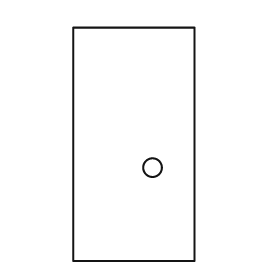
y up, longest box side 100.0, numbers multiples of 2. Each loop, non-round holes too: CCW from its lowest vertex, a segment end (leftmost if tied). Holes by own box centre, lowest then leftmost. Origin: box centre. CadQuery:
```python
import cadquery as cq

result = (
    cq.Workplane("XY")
    .moveTo(-26.0, -50.0)
    .lineTo(26.0, -50.0)
    .lineTo(26.0, 50.0)
    .lineTo(-26.0, 50.0)
    .close()
    .moveTo(8.0, -10.0)
    .circle(4.0)
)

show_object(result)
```